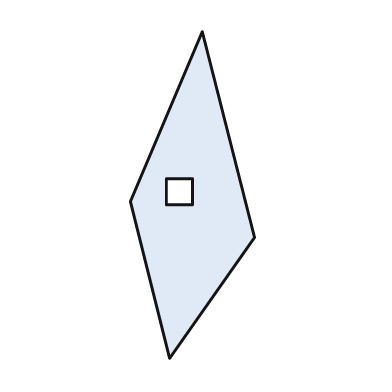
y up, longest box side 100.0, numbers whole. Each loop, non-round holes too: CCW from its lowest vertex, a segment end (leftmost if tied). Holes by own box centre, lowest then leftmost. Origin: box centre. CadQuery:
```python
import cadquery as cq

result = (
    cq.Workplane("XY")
    .moveTo(-7.0, -50.0)
    .lineTo(19.0, -13.0)
    .lineTo(3.0, 50.0)
    .lineTo(-19.0, -2.0)
    .close()
    .moveTo(-8.0, -3.0)
    .lineTo(0.0, -3.0)
    .lineTo(0.0, 5.0)
    .lineTo(-8.0, 5.0)
    .close()
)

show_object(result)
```